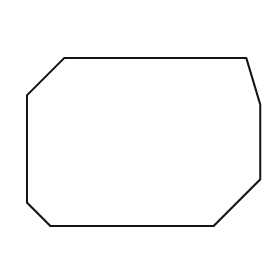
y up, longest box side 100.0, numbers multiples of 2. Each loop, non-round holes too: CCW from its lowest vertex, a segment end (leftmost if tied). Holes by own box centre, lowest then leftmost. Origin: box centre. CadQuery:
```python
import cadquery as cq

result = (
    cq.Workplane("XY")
    .moveTo(-40.0, -36.0)
    .lineTo(30.0, -36.0)
    .lineTo(50.0, -16.0)
    .lineTo(50.0, 16.0)
    .lineTo(44.0, 36.0)
    .lineTo(-34.0, 36.0)
    .lineTo(-50.0, 20.0)
    .lineTo(-50.0, -26.0)
    .close()
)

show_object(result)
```